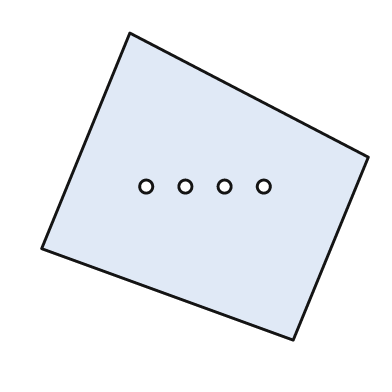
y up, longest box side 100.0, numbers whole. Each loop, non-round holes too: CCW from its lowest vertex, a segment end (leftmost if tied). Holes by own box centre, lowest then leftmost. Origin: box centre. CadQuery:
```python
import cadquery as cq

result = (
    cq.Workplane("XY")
    .moveTo(27.0, -47.0)
    .lineTo(50.0, 9.0)
    .lineTo(-23.0, 47.0)
    .lineTo(-50.0, -19.0)
    .close()
    .moveTo(-18.0, 0.0)
    .circle(2.0)
    .moveTo(-6.0, 0.0)
    .circle(2.0)
    .moveTo(6.0, 0.0)
    .circle(2.0)
    .moveTo(18.0, 0.0)
    .circle(2.0)
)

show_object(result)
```